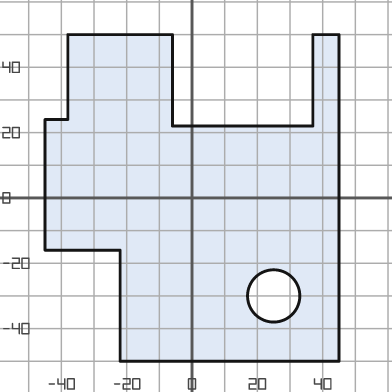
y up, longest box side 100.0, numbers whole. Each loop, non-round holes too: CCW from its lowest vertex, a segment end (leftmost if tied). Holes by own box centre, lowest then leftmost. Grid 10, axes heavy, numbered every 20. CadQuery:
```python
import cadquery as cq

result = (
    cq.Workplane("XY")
    .moveTo(-22.0, -50.0)
    .lineTo(45.0, -50.0)
    .lineTo(45.0, 50.0)
    .lineTo(37.0, 50.0)
    .lineTo(37.0, 22.0)
    .lineTo(-6.0, 22.0)
    .lineTo(-6.0, 50.0)
    .lineTo(-38.0, 50.0)
    .lineTo(-38.0, 24.0)
    .lineTo(-45.0, 24.0)
    .lineTo(-45.0, -16.0)
    .lineTo(-22.0, -16.0)
    .close()
    .moveTo(25.0, -30.0)
    .circle(8.0)
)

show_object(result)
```